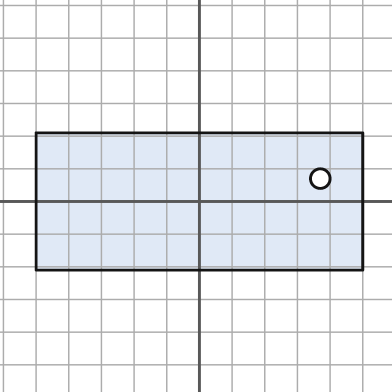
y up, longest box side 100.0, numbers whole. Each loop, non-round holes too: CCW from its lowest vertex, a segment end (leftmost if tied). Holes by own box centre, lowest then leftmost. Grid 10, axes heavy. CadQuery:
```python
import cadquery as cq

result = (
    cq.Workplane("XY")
    .moveTo(-50.0, -21.0)
    .lineTo(50.0, -21.0)
    .lineTo(50.0, 21.0)
    .lineTo(-50.0, 21.0)
    .close()
    .moveTo(37.0, 7.0)
    .circle(3.0)
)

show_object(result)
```